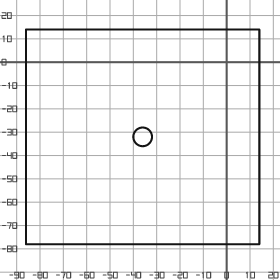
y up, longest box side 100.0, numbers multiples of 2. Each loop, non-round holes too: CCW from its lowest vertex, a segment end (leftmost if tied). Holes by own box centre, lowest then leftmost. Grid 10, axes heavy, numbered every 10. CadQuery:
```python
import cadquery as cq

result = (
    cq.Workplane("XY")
    .moveTo(-86.0, -78.0)
    .lineTo(14.0, -78.0)
    .lineTo(14.0, 14.0)
    .lineTo(-86.0, 14.0)
    .close()
    .moveTo(-36.0, -32.0)
    .circle(4.0)
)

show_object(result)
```